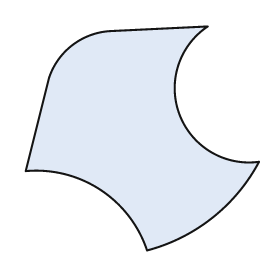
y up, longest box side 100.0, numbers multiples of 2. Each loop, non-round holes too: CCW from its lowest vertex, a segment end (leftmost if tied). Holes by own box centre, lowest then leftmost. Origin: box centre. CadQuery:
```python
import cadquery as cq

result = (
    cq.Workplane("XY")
    .moveTo(2.0, -48.0)
    .threePointArc((30.0, -34.0), (50.0, -10.0))
    .threePointArc((16.0, 10.0), (28.0, 48.0))
    .lineTo(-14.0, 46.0)
    .threePointArc((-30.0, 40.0), (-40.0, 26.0))
    .lineTo(-50.0, -14.0)
    .threePointArc((-18.0, -22.0), (2.0, -48.0))
    .close()
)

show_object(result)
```